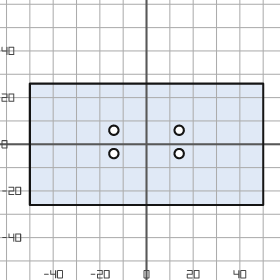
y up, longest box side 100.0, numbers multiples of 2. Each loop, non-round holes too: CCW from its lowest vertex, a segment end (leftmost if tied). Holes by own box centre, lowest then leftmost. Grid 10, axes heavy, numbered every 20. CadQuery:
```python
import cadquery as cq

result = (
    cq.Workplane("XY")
    .moveTo(-50.0, -26.0)
    .lineTo(50.0, -26.0)
    .lineTo(50.0, 26.0)
    .lineTo(-50.0, 26.0)
    .close()
    .moveTo(-14.0, -4.0)
    .circle(2.0)
    .moveTo(14.0, -4.0)
    .circle(2.0)
    .moveTo(-14.0, 6.0)
    .circle(2.0)
    .moveTo(14.0, 6.0)
    .circle(2.0)
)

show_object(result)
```